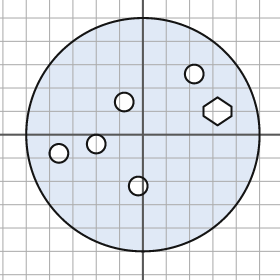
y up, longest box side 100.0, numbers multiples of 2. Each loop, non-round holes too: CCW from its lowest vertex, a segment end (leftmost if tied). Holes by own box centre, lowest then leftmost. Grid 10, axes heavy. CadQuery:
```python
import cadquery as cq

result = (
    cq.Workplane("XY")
    .moveTo(0.0, 0.0)
    .circle(50.0)
    .moveTo(-2.0, -22.0)
    .circle(4.0)
    .moveTo(-36.0, -8.0)
    .circle(4.0)
    .moveTo(-20.0, -4.0)
    .circle(4.0)
    .moveTo(32.0, 4.0)
    .lineTo(38.0, 8.0)
    .lineTo(38.0, 12.0)
    .lineTo(32.0, 16.0)
    .lineTo(26.0, 12.0)
    .lineTo(26.0, 8.0)
    .close()
    .moveTo(-8.0, 14.0)
    .circle(4.0)
    .moveTo(22.0, 26.0)
    .circle(4.0)
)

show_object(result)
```